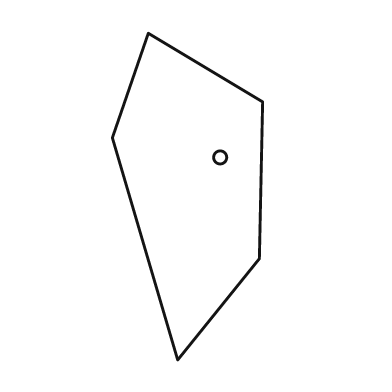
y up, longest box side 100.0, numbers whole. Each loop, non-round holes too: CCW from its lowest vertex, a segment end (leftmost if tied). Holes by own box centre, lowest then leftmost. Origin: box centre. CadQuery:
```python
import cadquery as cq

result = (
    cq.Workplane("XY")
    .moveTo(-3.0, -50.0)
    .lineTo(22.0, -19.0)
    .lineTo(23.0, 29.0)
    .lineTo(-12.0, 50.0)
    .lineTo(-23.0, 18.0)
    .close()
    .moveTo(10.0, 12.0)
    .circle(2.0)
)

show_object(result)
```